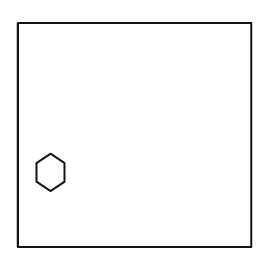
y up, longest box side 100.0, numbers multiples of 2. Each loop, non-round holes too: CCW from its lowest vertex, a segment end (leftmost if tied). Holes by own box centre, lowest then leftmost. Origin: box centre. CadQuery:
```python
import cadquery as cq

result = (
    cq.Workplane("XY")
    .moveTo(-50.0, -48.0)
    .lineTo(50.0, -48.0)
    .lineTo(50.0, 48.0)
    .lineTo(-50.0, 48.0)
    .close()
    .moveTo(-36.0, -24.0)
    .lineTo(-30.0, -20.0)
    .lineTo(-30.0, -12.0)
    .lineTo(-36.0, -8.0)
    .lineTo(-42.0, -12.0)
    .lineTo(-42.0, -20.0)
    .close()
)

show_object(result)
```